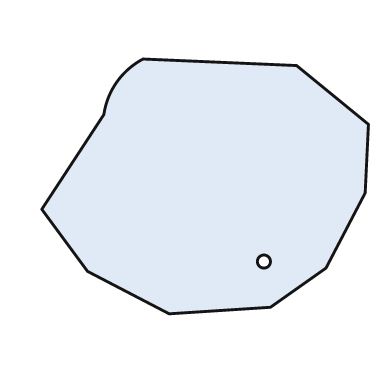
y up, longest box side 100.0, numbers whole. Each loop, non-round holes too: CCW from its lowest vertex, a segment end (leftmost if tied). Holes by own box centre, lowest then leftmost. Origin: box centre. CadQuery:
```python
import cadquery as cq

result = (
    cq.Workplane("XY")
    .moveTo(-11.0, -39.0)
    .lineTo(20.0, -37.0)
    .lineTo(37.0, -25.0)
    .lineTo(49.0, -2.0)
    .lineTo(50.0, 19.0)
    .lineTo(28.0, 37.0)
    .lineTo(-19.0, 39.0)
    .threePointArc((-27.0, 32.0), (-31.0, 22.0))
    .lineTo(-50.0, -7.0)
    .lineTo(-36.0, -26.0)
    .close()
    .moveTo(18.0, -23.0)
    .circle(2.0)
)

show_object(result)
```